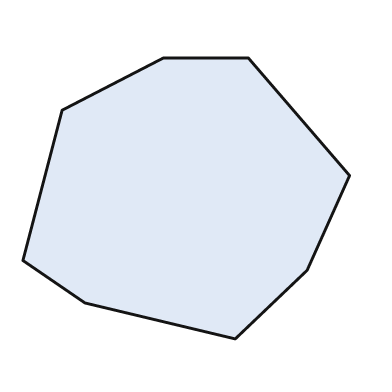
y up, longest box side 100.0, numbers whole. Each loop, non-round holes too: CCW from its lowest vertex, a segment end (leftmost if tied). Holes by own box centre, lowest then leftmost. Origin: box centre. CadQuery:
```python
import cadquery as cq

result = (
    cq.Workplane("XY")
    .moveTo(15.0, -43.0)
    .lineTo(37.0, -22.0)
    .lineTo(50.0, 7.0)
    .lineTo(19.0, 43.0)
    .lineTo(-7.0, 43.0)
    .lineTo(-38.0, 27.0)
    .lineTo(-50.0, -19.0)
    .lineTo(-31.0, -32.0)
    .close()
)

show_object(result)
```